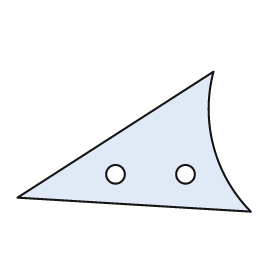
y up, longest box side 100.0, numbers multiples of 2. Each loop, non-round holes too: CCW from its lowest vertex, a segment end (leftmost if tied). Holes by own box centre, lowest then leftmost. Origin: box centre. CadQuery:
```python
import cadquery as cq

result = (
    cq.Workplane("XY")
    .moveTo(50.0, -30.0)
    .threePointArc((34.0, -2.0), (34.0, 30.0))
    .lineTo(-50.0, -24.0)
    .close()
    .moveTo(-8.0, -14.0)
    .circle(4.0)
    .moveTo(22.0, -14.0)
    .circle(4.0)
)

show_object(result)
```